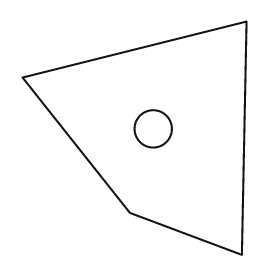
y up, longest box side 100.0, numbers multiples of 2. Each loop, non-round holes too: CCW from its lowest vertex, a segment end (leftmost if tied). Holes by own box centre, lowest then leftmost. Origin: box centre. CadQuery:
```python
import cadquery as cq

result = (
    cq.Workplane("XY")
    .moveTo(46.0, -50.0)
    .lineTo(48.0, 50.0)
    .lineTo(-48.0, 26.0)
    .lineTo(-2.0, -32.0)
    .close()
    .moveTo(8.0, 4.0)
    .circle(8.0)
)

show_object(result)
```